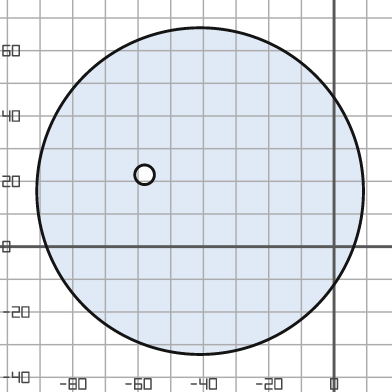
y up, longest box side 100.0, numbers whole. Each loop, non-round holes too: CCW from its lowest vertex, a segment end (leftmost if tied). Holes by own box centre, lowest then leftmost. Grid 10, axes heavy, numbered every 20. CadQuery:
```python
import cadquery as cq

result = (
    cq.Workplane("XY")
    .moveTo(-41.0, 17.0)
    .circle(50.0)
    .moveTo(-58.0, 22.0)
    .circle(3.0)
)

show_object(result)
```